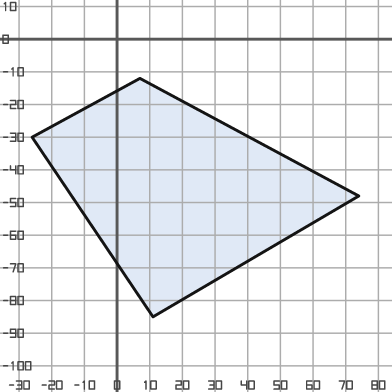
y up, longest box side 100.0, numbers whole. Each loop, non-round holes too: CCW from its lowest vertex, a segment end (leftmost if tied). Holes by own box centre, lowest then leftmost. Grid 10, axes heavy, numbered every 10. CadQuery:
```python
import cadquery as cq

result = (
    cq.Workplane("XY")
    .moveTo(11.0, -85.0)
    .lineTo(74.0, -48.0)
    .lineTo(7.0, -12.0)
    .lineTo(-26.0, -30.0)
    .close()
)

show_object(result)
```